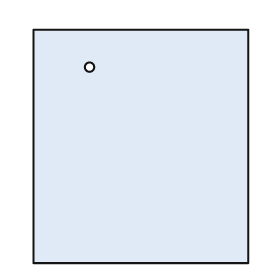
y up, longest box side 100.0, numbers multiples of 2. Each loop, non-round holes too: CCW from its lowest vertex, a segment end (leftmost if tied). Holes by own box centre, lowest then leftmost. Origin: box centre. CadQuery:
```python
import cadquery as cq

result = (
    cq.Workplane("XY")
    .moveTo(-46.0, -50.0)
    .lineTo(46.0, -50.0)
    .lineTo(46.0, 50.0)
    .lineTo(-46.0, 50.0)
    .close()
    .moveTo(-22.0, 34.0)
    .circle(2.0)
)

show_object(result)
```